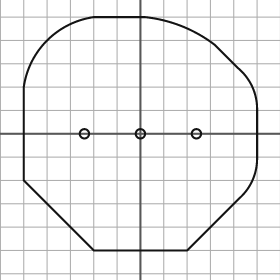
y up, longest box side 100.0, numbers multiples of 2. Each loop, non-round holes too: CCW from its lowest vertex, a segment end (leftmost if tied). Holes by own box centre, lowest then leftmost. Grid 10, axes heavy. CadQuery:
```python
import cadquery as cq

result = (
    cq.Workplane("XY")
    .moveTo(-20.0, -50.0)
    .lineTo(20.0, -50.0)
    .lineTo(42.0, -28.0)
    .threePointArc((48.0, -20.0), (50.0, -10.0))
    .lineTo(50.0, 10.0)
    .threePointArc((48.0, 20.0), (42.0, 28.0))
    .lineTo(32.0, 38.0)
    .threePointArc((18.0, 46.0), (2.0, 50.0))
    .lineTo(-20.0, 50.0)
    .threePointArc((-40.0, 40.0), (-50.0, 20.0))
    .lineTo(-50.0, -20.0)
    .close()
    .moveTo(-24.0, 0.0)
    .circle(2.0)
    .moveTo(0.0, 0.0)
    .circle(2.0)
    .moveTo(24.0, 0.0)
    .circle(2.0)
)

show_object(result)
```